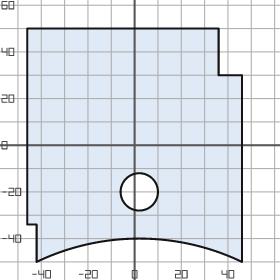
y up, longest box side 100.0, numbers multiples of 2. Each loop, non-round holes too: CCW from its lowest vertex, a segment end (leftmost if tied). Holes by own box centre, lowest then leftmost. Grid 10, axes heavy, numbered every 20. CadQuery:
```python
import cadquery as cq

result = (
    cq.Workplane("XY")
    .moveTo(-42.0, -50.0)
    .threePointArc((2.0, -40.0), (46.0, -50.0))
    .lineTo(46.0, 30.0)
    .lineTo(36.0, 30.0)
    .lineTo(36.0, 50.0)
    .lineTo(-46.0, 50.0)
    .lineTo(-46.0, -34.0)
    .lineTo(-42.0, -34.0)
    .close()
    .moveTo(2.0, -20.0)
    .circle(8.0)
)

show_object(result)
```